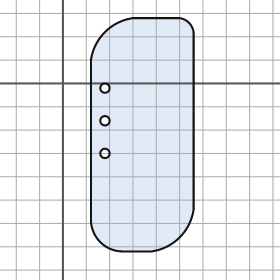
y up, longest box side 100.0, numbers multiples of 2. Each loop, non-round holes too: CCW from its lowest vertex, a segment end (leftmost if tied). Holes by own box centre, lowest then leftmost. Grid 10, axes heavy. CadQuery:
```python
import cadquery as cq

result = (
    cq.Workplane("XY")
    .moveTo(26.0, -72.0)
    .lineTo(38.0, -72.0)
    .threePointArc((50.0, -66.0), (56.0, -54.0))
    .lineTo(56.0, 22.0)
    .threePointArc((54.0, 26.0), (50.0, 28.0))
    .lineTo(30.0, 28.0)
    .threePointArc((18.0, 22.0), (12.0, 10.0))
    .lineTo(12.0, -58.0)
    .threePointArc((16.0, -68.0), (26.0, -72.0))
    .close()
    .moveTo(18.0, -30.0)
    .circle(2.0)
    .moveTo(18.0, -16.0)
    .circle(2.0)
    .moveTo(18.0, -2.0)
    .circle(2.0)
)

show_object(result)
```